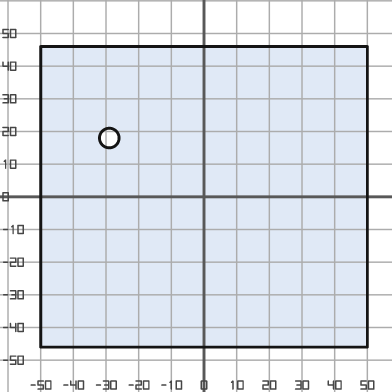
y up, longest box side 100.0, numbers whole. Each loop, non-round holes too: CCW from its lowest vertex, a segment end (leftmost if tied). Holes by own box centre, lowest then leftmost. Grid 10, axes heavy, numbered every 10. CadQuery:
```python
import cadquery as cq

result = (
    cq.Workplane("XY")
    .moveTo(-50.0, -46.0)
    .lineTo(50.0, -46.0)
    .lineTo(50.0, 46.0)
    .lineTo(-50.0, 46.0)
    .close()
    .moveTo(-29.0, 18.0)
    .circle(3.0)
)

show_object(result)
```